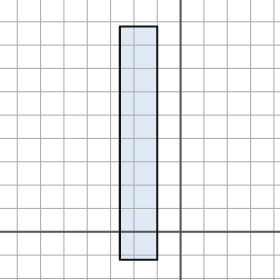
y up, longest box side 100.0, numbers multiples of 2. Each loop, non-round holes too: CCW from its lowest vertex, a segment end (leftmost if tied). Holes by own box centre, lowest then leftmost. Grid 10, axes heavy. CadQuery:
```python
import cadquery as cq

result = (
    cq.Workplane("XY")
    .moveTo(-26.0, -12.0)
    .lineTo(-10.0, -12.0)
    .lineTo(-10.0, 88.0)
    .lineTo(-26.0, 88.0)
    .close()
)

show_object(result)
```